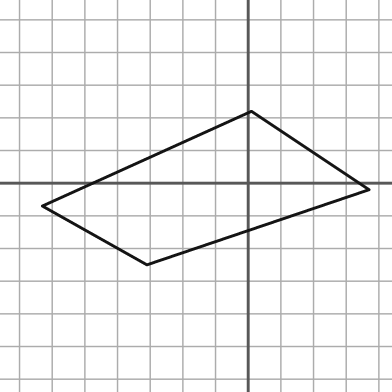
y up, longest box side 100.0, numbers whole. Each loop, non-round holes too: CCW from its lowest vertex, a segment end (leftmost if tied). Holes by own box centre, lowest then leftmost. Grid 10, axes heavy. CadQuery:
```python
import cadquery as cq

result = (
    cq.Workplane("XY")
    .moveTo(-31.0, -25.0)
    .lineTo(37.0, -2.0)
    .lineTo(1.0, 22.0)
    .lineTo(-63.0, -7.0)
    .close()
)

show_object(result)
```